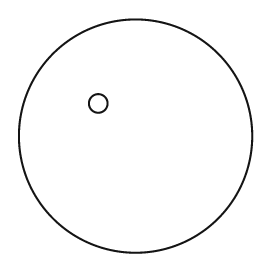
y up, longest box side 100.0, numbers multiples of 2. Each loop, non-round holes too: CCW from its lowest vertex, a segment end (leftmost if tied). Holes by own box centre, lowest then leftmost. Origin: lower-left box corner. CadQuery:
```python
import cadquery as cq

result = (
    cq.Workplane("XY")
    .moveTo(50.0, 50.0)
    .circle(50.0)
    .moveTo(34.0, 64.0)
    .circle(4.0)
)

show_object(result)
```